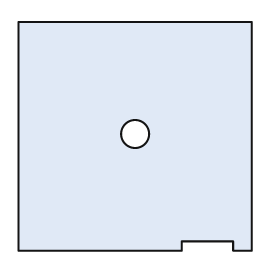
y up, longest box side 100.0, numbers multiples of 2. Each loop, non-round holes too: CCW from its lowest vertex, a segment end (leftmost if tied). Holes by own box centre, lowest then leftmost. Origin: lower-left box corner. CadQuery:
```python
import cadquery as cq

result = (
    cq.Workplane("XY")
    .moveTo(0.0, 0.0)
    .lineTo(70.0, 0.0)
    .lineTo(70.0, 4.0)
    .lineTo(92.0, 4.0)
    .lineTo(92.0, 0.0)
    .lineTo(100.0, 0.0)
    .lineTo(100.0, 98.0)
    .lineTo(0.0, 98.0)
    .close()
    .moveTo(50.0, 50.0)
    .circle(6.0)
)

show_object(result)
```